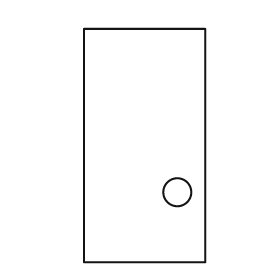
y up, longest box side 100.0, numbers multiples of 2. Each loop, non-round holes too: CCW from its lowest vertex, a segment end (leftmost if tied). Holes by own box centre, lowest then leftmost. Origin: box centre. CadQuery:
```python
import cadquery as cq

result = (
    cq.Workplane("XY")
    .moveTo(-26.0, -50.0)
    .lineTo(26.0, -50.0)
    .lineTo(26.0, 50.0)
    .lineTo(-26.0, 50.0)
    .close()
    .moveTo(14.0, -20.0)
    .circle(6.0)
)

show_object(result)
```